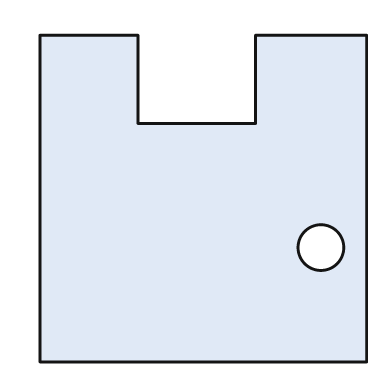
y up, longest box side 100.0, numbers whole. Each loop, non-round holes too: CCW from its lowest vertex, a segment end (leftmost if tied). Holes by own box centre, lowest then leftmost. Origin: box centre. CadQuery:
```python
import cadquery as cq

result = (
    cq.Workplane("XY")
    .moveTo(-50.0, -50.0)
    .lineTo(50.0, -50.0)
    .lineTo(50.0, 50.0)
    .lineTo(16.0, 50.0)
    .lineTo(16.0, 23.0)
    .lineTo(-20.0, 23.0)
    .lineTo(-20.0, 50.0)
    .lineTo(-50.0, 50.0)
    .close()
    .moveTo(36.0, -15.0)
    .circle(7.0)
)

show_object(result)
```